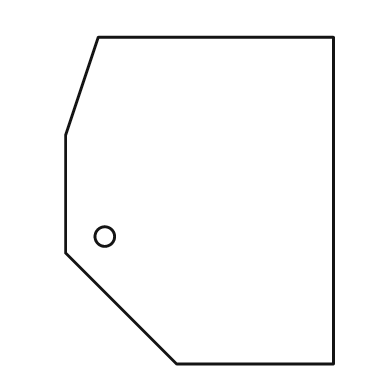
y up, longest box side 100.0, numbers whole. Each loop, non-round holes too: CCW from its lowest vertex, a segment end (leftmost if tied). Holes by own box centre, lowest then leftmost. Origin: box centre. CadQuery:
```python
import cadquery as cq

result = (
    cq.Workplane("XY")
    .moveTo(-7.0, -50.0)
    .lineTo(41.0, -50.0)
    .lineTo(41.0, 50.0)
    .lineTo(-31.0, 50.0)
    .lineTo(-41.0, 20.0)
    .lineTo(-41.0, -16.0)
    .close()
    .moveTo(-29.0, -11.0)
    .circle(3.0)
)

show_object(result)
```